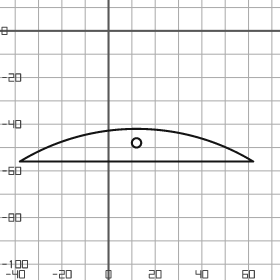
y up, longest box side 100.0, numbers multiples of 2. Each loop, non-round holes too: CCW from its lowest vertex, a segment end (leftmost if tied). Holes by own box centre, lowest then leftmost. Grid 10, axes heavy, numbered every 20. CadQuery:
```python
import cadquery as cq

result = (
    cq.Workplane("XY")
    .moveTo(-38.0, -56.0)
    .lineTo(62.0, -56.0)
    .threePointArc((12.0, -42.0), (-38.0, -56.0))
    .close()
    .moveTo(12.0, -48.0)
    .circle(2.0)
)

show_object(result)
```